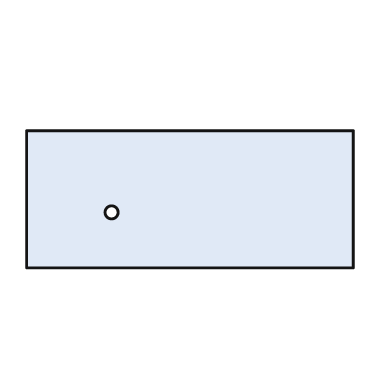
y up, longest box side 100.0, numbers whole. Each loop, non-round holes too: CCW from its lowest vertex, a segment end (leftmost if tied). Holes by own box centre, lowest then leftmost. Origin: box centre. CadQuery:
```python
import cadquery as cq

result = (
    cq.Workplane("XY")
    .moveTo(-50.0, -21.0)
    .lineTo(50.0, -21.0)
    .lineTo(50.0, 21.0)
    .lineTo(-50.0, 21.0)
    .close()
    .moveTo(-24.0, -4.0)
    .circle(2.0)
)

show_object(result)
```